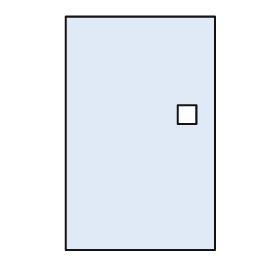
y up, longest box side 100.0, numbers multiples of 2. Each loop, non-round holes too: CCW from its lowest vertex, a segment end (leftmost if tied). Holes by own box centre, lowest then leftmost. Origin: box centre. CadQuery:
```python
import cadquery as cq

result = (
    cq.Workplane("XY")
    .moveTo(-32.0, -50.0)
    .lineTo(32.0, -50.0)
    .lineTo(32.0, 50.0)
    .lineTo(-32.0, 50.0)
    .close()
    .moveTo(16.0, 4.0)
    .lineTo(24.0, 4.0)
    .lineTo(24.0, 12.0)
    .lineTo(16.0, 12.0)
    .close()
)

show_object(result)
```